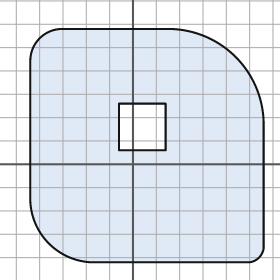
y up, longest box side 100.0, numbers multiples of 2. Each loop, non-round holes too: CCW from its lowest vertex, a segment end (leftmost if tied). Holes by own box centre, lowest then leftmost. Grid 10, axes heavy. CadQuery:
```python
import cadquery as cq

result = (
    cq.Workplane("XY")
    .moveTo(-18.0, -42.0)
    .lineTo(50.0, -42.0)
    .threePointArc((54.0, -40.0), (56.0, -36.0))
    .lineTo(56.0, 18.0)
    .threePointArc((44.0, 46.0), (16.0, 58.0))
    .lineTo(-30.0, 58.0)
    .threePointArc((-40.0, 54.0), (-44.0, 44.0))
    .lineTo(-44.0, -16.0)
    .threePointArc((-36.0, -34.0), (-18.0, -42.0))
    .close()
    .moveTo(-6.0, 6.0)
    .lineTo(14.0, 6.0)
    .lineTo(14.0, 26.0)
    .lineTo(-6.0, 26.0)
    .close()
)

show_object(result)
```